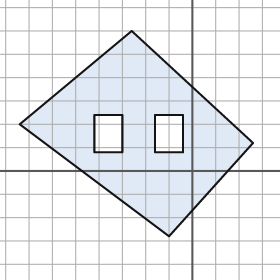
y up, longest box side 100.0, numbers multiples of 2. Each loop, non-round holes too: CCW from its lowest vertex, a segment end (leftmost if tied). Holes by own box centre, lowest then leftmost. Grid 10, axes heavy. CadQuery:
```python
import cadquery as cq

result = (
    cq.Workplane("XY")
    .moveTo(-10.0, -28.0)
    .lineTo(26.0, 12.0)
    .lineTo(-26.0, 60.0)
    .lineTo(-74.0, 20.0)
    .close()
    .moveTo(-42.0, 8.0)
    .lineTo(-30.0, 8.0)
    .lineTo(-30.0, 24.0)
    .lineTo(-42.0, 24.0)
    .close()
    .moveTo(-16.0, 8.0)
    .lineTo(-4.0, 8.0)
    .lineTo(-4.0, 24.0)
    .lineTo(-16.0, 24.0)
    .close()
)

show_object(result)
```